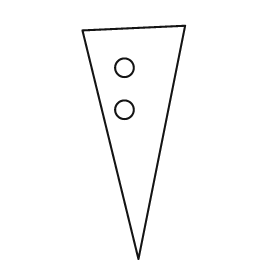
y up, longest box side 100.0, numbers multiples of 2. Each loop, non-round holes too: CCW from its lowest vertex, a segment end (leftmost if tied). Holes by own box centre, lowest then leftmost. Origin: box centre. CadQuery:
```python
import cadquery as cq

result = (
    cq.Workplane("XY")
    .moveTo(2.0, -50.0)
    .lineTo(22.0, 50.0)
    .lineTo(-22.0, 48.0)
    .close()
    .moveTo(-4.0, 14.0)
    .circle(4.0)
    .moveTo(-4.0, 32.0)
    .circle(4.0)
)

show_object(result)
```